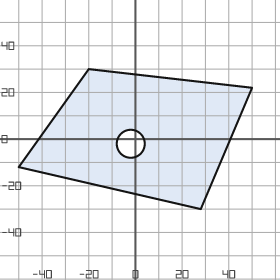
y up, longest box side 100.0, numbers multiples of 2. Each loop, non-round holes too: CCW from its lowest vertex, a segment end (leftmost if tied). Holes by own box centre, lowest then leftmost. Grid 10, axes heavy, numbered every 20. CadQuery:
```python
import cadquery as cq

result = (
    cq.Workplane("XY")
    .moveTo(28.0, -30.0)
    .lineTo(50.0, 22.0)
    .lineTo(-20.0, 30.0)
    .lineTo(-50.0, -12.0)
    .close()
    .moveTo(-2.0, -2.0)
    .circle(6.0)
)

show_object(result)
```